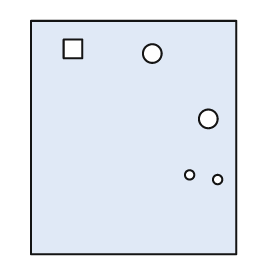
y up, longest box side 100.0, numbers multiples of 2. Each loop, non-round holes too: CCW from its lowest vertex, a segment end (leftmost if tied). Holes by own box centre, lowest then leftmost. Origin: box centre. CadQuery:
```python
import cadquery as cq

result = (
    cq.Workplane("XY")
    .moveTo(-44.0, -50.0)
    .lineTo(44.0, -50.0)
    .lineTo(44.0, 50.0)
    .lineTo(-44.0, 50.0)
    .close()
    .moveTo(36.0, -18.0)
    .circle(2.0)
    .moveTo(24.0, -16.0)
    .circle(2.0)
    .moveTo(32.0, 8.0)
    .circle(4.0)
    .moveTo(8.0, 36.0)
    .circle(4.0)
    .moveTo(-30.0, 34.0)
    .lineTo(-22.0, 34.0)
    .lineTo(-22.0, 42.0)
    .lineTo(-30.0, 42.0)
    .close()
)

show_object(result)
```